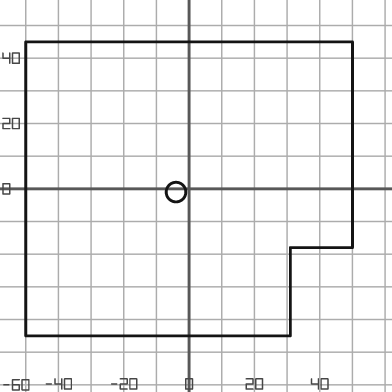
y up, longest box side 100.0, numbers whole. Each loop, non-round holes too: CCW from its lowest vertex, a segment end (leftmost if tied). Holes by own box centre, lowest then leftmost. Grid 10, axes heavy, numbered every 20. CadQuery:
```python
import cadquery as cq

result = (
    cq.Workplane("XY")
    .moveTo(-50.0, -45.0)
    .lineTo(31.0, -45.0)
    .lineTo(31.0, -18.0)
    .lineTo(50.0, -18.0)
    .lineTo(50.0, 45.0)
    .lineTo(-50.0, 45.0)
    .close()
    .moveTo(-4.0, -1.0)
    .circle(3.0)
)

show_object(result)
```